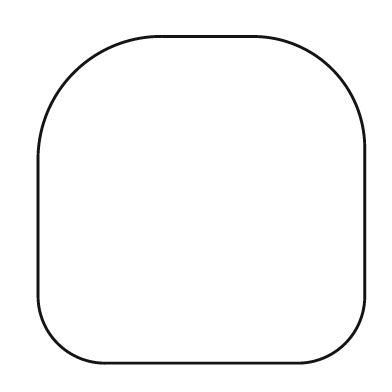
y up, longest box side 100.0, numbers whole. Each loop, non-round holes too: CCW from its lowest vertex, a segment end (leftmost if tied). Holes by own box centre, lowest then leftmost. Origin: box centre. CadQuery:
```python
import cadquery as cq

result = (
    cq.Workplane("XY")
    .moveTo(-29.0, -50.0)
    .lineTo(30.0, -50.0)
    .threePointArc((44.0, -44.0), (50.0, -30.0))
    .lineTo(50.0, 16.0)
    .threePointArc((40.0, 40.0), (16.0, 50.0))
    .lineTo(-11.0, 50.0)
    .threePointArc((-39.0, 39.0), (-50.0, 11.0))
    .lineTo(-50.0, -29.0)
    .threePointArc((-44.0, -44.0), (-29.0, -50.0))
    .close()
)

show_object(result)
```